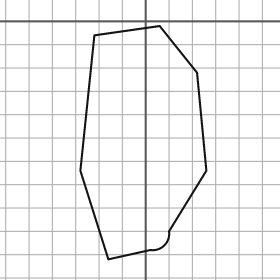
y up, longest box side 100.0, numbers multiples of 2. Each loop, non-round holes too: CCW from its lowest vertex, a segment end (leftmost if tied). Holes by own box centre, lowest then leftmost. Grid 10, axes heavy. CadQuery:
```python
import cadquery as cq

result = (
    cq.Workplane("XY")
    .moveTo(-16.0, -102.0)
    .lineTo(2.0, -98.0)
    .threePointArc((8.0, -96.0), (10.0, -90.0))
    .lineTo(26.0, -64.0)
    .lineTo(22.0, -22.0)
    .lineTo(6.0, -2.0)
    .lineTo(-22.0, -6.0)
    .lineTo(-28.0, -64.0)
    .close()
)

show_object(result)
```